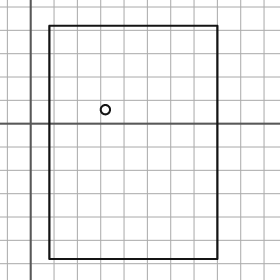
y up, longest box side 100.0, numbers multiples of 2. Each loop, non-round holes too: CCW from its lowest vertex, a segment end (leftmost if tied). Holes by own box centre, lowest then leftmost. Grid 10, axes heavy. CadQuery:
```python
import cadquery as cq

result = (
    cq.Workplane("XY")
    .moveTo(8.0, -58.0)
    .lineTo(80.0, -58.0)
    .lineTo(80.0, 42.0)
    .lineTo(8.0, 42.0)
    .close()
    .moveTo(32.0, 6.0)
    .circle(2.0)
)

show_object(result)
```